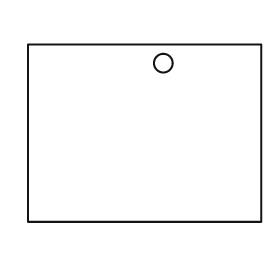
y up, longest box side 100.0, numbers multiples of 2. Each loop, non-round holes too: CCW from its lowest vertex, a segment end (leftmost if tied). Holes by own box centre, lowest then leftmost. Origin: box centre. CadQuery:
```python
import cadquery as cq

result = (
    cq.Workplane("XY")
    .moveTo(-50.0, -38.0)
    .lineTo(50.0, -38.0)
    .lineTo(50.0, 38.0)
    .lineTo(-50.0, 38.0)
    .close()
    .moveTo(8.0, 30.0)
    .circle(4.0)
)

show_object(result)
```